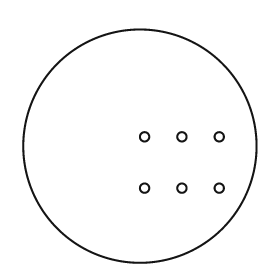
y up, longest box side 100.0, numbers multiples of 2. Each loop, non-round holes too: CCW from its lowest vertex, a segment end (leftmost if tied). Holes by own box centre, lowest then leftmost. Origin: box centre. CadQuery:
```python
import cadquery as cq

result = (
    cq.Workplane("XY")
    .moveTo(0.0, 0.0)
    .circle(50.0)
    .moveTo(2.0, -18.0)
    .circle(2.0)
    .moveTo(18.0, -18.0)
    .circle(2.0)
    .moveTo(34.0, -18.0)
    .circle(2.0)
    .moveTo(2.0, 4.0)
    .circle(2.0)
    .moveTo(18.0, 4.0)
    .circle(2.0)
    .moveTo(34.0, 4.0)
    .circle(2.0)
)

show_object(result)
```